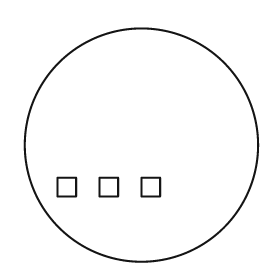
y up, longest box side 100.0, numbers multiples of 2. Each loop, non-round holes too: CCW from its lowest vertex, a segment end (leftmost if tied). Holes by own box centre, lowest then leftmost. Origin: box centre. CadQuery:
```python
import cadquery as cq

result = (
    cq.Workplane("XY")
    .moveTo(0.0, 0.0)
    .circle(50.0)
    .moveTo(-36.0, -22.0)
    .lineTo(-28.0, -22.0)
    .lineTo(-28.0, -14.0)
    .lineTo(-36.0, -14.0)
    .close()
    .moveTo(-18.0, -22.0)
    .lineTo(-10.0, -22.0)
    .lineTo(-10.0, -14.0)
    .lineTo(-18.0, -14.0)
    .close()
    .moveTo(0.0, -22.0)
    .lineTo(8.0, -22.0)
    .lineTo(8.0, -14.0)
    .lineTo(0.0, -14.0)
    .close()
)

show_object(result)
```